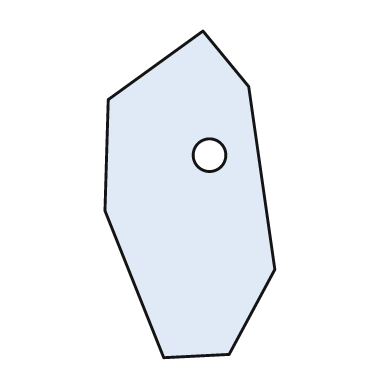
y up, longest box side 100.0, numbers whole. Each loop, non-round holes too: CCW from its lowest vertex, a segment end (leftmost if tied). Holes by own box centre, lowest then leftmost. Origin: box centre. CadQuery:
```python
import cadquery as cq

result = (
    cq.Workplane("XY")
    .moveTo(-8.0, -50.0)
    .lineTo(12.0, -49.0)
    .lineTo(26.0, -23.0)
    .lineTo(18.0, 33.0)
    .lineTo(4.0, 50.0)
    .lineTo(-25.0, 29.0)
    .lineTo(-26.0, -5.0)
    .close()
    .moveTo(6.0, 12.0)
    .circle(5.0)
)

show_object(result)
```